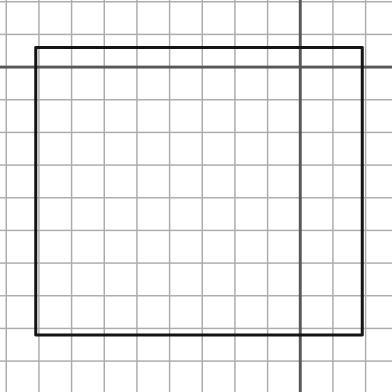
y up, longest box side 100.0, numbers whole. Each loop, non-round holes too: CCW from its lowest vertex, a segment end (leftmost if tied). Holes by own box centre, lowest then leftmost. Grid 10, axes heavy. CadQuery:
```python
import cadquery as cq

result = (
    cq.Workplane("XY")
    .moveTo(-81.0, -82.0)
    .lineTo(19.0, -82.0)
    .lineTo(19.0, 6.0)
    .lineTo(-81.0, 6.0)
    .close()
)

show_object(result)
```